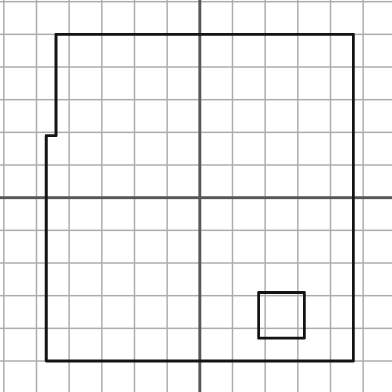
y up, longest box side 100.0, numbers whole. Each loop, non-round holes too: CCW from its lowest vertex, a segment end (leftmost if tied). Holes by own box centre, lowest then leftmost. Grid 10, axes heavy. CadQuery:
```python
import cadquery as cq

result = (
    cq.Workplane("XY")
    .moveTo(-47.0, -50.0)
    .lineTo(47.0, -50.0)
    .lineTo(47.0, 50.0)
    .lineTo(-44.0, 50.0)
    .lineTo(-44.0, 19.0)
    .lineTo(-47.0, 19.0)
    .close()
    .moveTo(18.0, -43.0)
    .lineTo(32.0, -43.0)
    .lineTo(32.0, -29.0)
    .lineTo(18.0, -29.0)
    .close()
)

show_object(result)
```